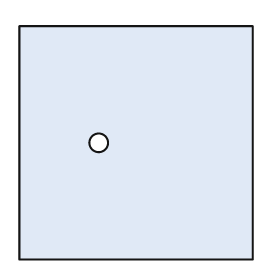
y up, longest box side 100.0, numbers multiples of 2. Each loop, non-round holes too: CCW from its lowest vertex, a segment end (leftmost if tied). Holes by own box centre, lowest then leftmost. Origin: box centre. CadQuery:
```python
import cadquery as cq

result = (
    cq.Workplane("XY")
    .moveTo(-50.0, -50.0)
    .lineTo(50.0, -50.0)
    .lineTo(50.0, 50.0)
    .lineTo(-50.0, 50.0)
    .close()
    .moveTo(-16.0, 0.0)
    .circle(4.0)
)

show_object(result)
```